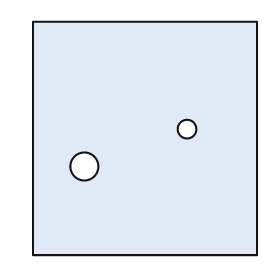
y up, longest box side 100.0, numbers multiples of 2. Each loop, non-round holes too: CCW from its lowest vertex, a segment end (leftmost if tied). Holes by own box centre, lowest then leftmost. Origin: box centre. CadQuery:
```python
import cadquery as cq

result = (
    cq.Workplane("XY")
    .moveTo(-48.0, -50.0)
    .lineTo(48.0, -50.0)
    .lineTo(48.0, 50.0)
    .lineTo(-48.0, 50.0)
    .close()
    .moveTo(-26.0, -12.0)
    .circle(6.0)
    .moveTo(18.0, 4.0)
    .circle(4.0)
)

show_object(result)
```